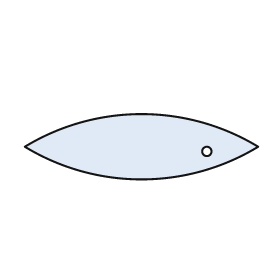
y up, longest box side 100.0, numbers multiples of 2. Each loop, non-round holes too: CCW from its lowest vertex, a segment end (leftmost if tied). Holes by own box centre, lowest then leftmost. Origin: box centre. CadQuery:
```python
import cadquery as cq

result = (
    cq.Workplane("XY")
    .moveTo(-50.0, 0.0)
    .threePointArc((0.0, -14.0), (50.0, 0.0))
    .threePointArc((0.0, 14.0), (-50.0, 0.0))
    .close()
    .moveTo(28.0, -2.0)
    .circle(2.0)
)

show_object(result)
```